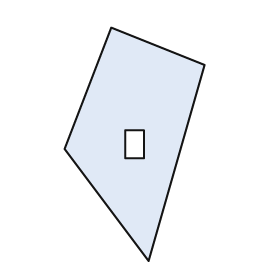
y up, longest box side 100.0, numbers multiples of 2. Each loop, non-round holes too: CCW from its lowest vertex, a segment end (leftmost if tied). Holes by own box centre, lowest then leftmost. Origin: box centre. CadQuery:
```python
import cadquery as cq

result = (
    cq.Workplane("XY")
    .moveTo(6.0, -50.0)
    .lineTo(30.0, 34.0)
    .lineTo(-10.0, 50.0)
    .lineTo(-30.0, -2.0)
    .close()
    .moveTo(-4.0, -6.0)
    .lineTo(4.0, -6.0)
    .lineTo(4.0, 6.0)
    .lineTo(-4.0, 6.0)
    .close()
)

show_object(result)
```